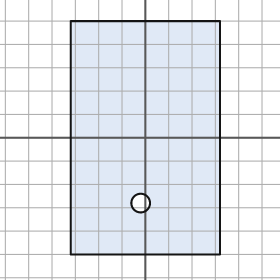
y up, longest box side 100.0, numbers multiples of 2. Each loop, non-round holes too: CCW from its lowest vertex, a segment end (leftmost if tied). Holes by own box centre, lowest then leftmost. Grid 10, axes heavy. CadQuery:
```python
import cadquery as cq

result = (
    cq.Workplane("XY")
    .moveTo(-32.0, -50.0)
    .lineTo(32.0, -50.0)
    .lineTo(32.0, 50.0)
    .lineTo(-32.0, 50.0)
    .close()
    .moveTo(-2.0, -28.0)
    .circle(4.0)
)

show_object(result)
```